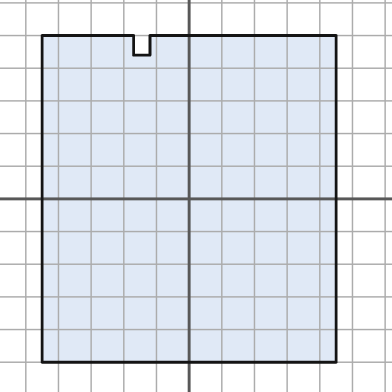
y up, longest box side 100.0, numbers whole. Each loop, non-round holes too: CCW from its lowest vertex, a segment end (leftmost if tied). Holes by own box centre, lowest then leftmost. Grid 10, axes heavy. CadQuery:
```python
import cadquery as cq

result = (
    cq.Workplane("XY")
    .moveTo(-45.0, -50.0)
    .lineTo(45.0, -50.0)
    .lineTo(45.0, 50.0)
    .lineTo(-12.0, 50.0)
    .lineTo(-12.0, 44.0)
    .lineTo(-17.0, 44.0)
    .lineTo(-17.0, 50.0)
    .lineTo(-45.0, 50.0)
    .close()
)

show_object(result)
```